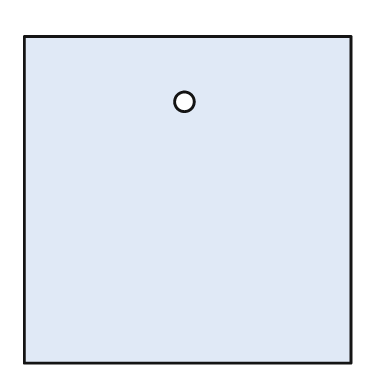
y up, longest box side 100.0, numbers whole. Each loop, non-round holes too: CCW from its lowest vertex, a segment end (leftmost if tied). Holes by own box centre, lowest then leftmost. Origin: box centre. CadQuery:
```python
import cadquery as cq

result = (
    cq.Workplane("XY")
    .moveTo(-50.0, -50.0)
    .lineTo(50.0, -50.0)
    .lineTo(50.0, 50.0)
    .lineTo(-50.0, 50.0)
    .close()
    .moveTo(-1.0, 30.0)
    .circle(3.0)
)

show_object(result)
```